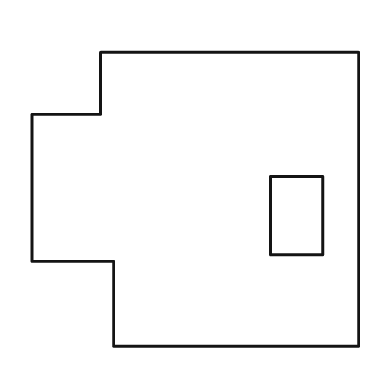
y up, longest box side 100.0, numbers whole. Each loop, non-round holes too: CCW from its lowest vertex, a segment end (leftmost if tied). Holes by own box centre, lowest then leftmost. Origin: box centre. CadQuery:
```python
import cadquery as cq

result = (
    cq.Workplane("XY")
    .moveTo(-25.0, -45.0)
    .lineTo(50.0, -45.0)
    .lineTo(50.0, 45.0)
    .lineTo(-29.0, 45.0)
    .lineTo(-29.0, 26.0)
    .lineTo(-50.0, 26.0)
    .lineTo(-50.0, -19.0)
    .lineTo(-25.0, -19.0)
    .close()
    .moveTo(23.0, -17.0)
    .lineTo(39.0, -17.0)
    .lineTo(39.0, 7.0)
    .lineTo(23.0, 7.0)
    .close()
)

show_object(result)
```